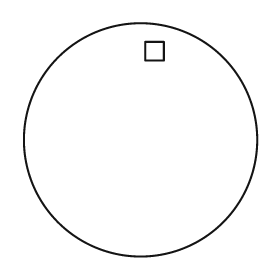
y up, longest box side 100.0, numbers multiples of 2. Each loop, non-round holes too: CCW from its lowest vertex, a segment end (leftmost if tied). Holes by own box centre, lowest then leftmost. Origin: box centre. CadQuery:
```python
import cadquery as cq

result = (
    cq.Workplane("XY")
    .moveTo(0.0, 0.0)
    .circle(50.0)
    .moveTo(2.0, 34.0)
    .lineTo(10.0, 34.0)
    .lineTo(10.0, 42.0)
    .lineTo(2.0, 42.0)
    .close()
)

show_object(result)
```